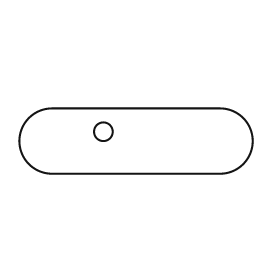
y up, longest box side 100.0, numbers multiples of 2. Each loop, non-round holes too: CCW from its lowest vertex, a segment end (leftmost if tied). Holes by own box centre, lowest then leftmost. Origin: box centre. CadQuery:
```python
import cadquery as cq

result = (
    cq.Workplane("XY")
    .moveTo(-36.0, -14.0)
    .lineTo(36.0, -14.0)
    .threePointArc((50.0, 0.0), (36.0, 14.0))
    .lineTo(-36.0, 14.0)
    .threePointArc((-50.0, 0.0), (-36.0, -14.0))
    .close()
    .moveTo(-14.0, 4.0)
    .circle(4.0)
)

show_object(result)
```